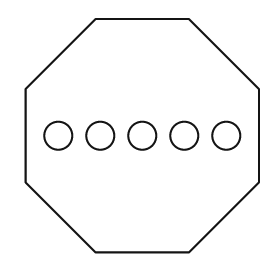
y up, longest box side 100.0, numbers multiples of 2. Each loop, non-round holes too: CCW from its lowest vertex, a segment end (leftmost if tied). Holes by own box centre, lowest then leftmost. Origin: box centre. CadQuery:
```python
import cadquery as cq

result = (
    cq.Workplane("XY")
    .moveTo(-20.0, -50.0)
    .lineTo(20.0, -50.0)
    .lineTo(50.0, -20.0)
    .lineTo(50.0, 20.0)
    .lineTo(20.0, 50.0)
    .lineTo(-20.0, 50.0)
    .lineTo(-50.0, 20.0)
    .lineTo(-50.0, -20.0)
    .close()
    .moveTo(-36.0, 0.0)
    .circle(6.0)
    .moveTo(-18.0, 0.0)
    .circle(6.0)
    .moveTo(0.0, 0.0)
    .circle(6.0)
    .moveTo(18.0, 0.0)
    .circle(6.0)
    .moveTo(36.0, 0.0)
    .circle(6.0)
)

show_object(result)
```